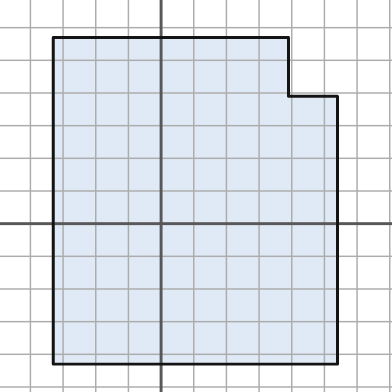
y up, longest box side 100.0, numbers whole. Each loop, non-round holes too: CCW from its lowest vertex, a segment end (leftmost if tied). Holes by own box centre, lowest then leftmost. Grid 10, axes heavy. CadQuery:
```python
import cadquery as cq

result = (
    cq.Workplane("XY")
    .moveTo(-33.0, -43.0)
    .lineTo(54.0, -43.0)
    .lineTo(54.0, 39.0)
    .lineTo(39.0, 39.0)
    .lineTo(39.0, 57.0)
    .lineTo(-33.0, 57.0)
    .close()
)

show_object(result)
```